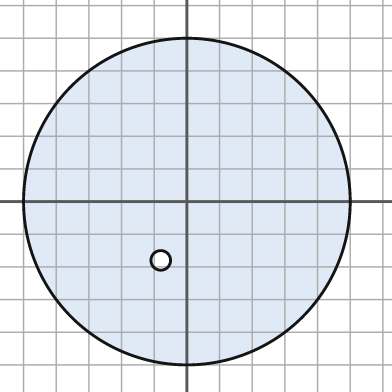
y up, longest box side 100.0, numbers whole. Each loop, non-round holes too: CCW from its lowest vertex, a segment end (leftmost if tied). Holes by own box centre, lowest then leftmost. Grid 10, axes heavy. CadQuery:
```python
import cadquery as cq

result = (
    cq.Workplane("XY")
    .moveTo(0.0, 0.0)
    .circle(50.0)
    .moveTo(-8.0, -18.0)
    .circle(3.0)
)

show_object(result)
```